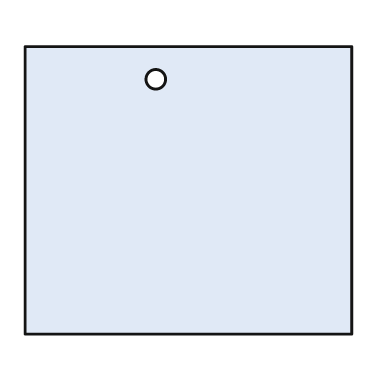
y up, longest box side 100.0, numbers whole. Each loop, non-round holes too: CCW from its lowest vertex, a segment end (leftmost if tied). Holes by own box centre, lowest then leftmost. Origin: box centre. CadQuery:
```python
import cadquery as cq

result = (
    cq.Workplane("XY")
    .moveTo(-50.0, -44.0)
    .lineTo(50.0, -44.0)
    .lineTo(50.0, 44.0)
    .lineTo(-50.0, 44.0)
    .close()
    .moveTo(-10.0, 34.0)
    .circle(3.0)
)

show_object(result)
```